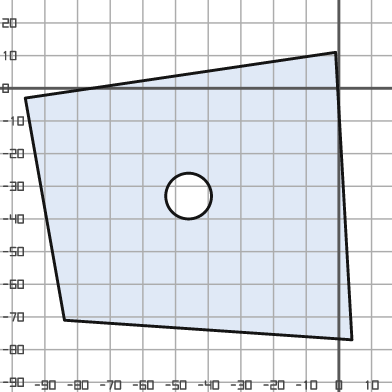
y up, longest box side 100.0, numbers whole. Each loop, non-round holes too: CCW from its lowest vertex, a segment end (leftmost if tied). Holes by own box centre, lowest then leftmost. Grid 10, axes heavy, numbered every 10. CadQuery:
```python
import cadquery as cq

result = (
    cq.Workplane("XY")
    .moveTo(4.0, -77.0)
    .lineTo(-1.0, 11.0)
    .lineTo(-96.0, -3.0)
    .lineTo(-84.0, -71.0)
    .close()
    .moveTo(-46.0, -33.0)
    .circle(7.0)
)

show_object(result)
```